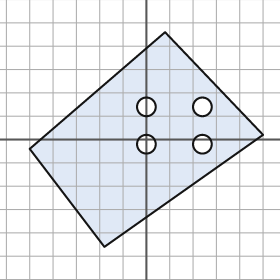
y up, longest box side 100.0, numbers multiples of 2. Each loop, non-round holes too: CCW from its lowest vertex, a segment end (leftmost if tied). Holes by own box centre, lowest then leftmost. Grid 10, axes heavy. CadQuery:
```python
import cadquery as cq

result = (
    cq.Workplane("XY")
    .moveTo(-18.0, -46.0)
    .lineTo(50.0, 2.0)
    .lineTo(8.0, 46.0)
    .lineTo(-50.0, -4.0)
    .close()
    .moveTo(0.0, -2.0)
    .circle(4.0)
    .moveTo(24.0, -2.0)
    .circle(4.0)
    .moveTo(0.0, 14.0)
    .circle(4.0)
    .moveTo(24.0, 14.0)
    .circle(4.0)
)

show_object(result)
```